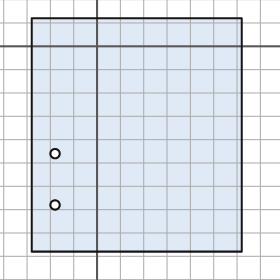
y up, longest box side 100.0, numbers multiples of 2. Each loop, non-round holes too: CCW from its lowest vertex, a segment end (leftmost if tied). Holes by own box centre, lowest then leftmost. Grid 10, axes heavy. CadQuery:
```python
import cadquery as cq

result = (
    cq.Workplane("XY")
    .moveTo(-28.0, -88.0)
    .lineTo(62.0, -88.0)
    .lineTo(62.0, 12.0)
    .lineTo(-28.0, 12.0)
    .close()
    .moveTo(-18.0, -68.0)
    .circle(2.0)
    .moveTo(-18.0, -46.0)
    .circle(2.0)
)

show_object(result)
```